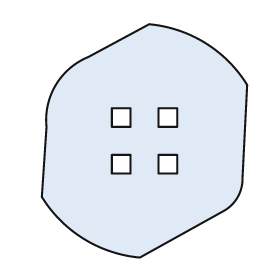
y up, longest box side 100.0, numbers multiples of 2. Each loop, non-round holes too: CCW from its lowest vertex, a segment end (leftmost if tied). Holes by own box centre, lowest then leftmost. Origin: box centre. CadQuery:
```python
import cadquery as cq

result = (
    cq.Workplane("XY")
    .moveTo(-2.0, -50.0)
    .lineTo(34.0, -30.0)
    .threePointArc((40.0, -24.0), (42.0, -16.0))
    .lineTo(44.0, 24.0)
    .threePointArc((26.0, 42.0), (2.0, 50.0))
    .lineTo(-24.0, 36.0)
    .threePointArc((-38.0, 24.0), (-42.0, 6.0))
    .lineTo(-44.0, -24.0)
    .threePointArc((-26.0, -42.0), (-2.0, -50.0))
    .close()
    .moveTo(-14.0, -14.0)
    .lineTo(-6.0, -14.0)
    .lineTo(-6.0, -6.0)
    .lineTo(-14.0, -6.0)
    .close()
    .moveTo(6.0, -14.0)
    .lineTo(14.0, -14.0)
    .lineTo(14.0, -6.0)
    .lineTo(6.0, -6.0)
    .close()
    .moveTo(-14.0, 6.0)
    .lineTo(-6.0, 6.0)
    .lineTo(-6.0, 14.0)
    .lineTo(-14.0, 14.0)
    .close()
    .moveTo(6.0, 6.0)
    .lineTo(14.0, 6.0)
    .lineTo(14.0, 14.0)
    .lineTo(6.0, 14.0)
    .close()
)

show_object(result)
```